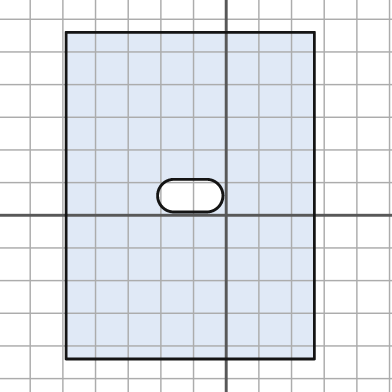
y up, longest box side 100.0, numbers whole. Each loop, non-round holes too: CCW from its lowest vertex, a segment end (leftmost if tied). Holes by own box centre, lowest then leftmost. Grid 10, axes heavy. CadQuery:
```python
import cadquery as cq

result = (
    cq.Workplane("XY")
    .moveTo(-49.0, -44.0)
    .lineTo(27.0, -44.0)
    .lineTo(27.0, 56.0)
    .lineTo(-49.0, 56.0)
    .close()
    .moveTo(-16.0, 1.0)
    .lineTo(-6.0, 1.0)
    .threePointArc((-1.0, 6.0), (-6.0, 11.0))
    .lineTo(-16.0, 11.0)
    .threePointArc((-21.0, 6.0), (-16.0, 1.0))
    .close()
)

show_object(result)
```